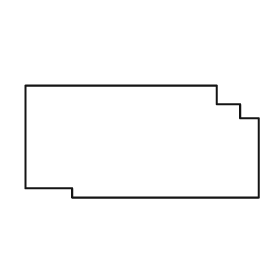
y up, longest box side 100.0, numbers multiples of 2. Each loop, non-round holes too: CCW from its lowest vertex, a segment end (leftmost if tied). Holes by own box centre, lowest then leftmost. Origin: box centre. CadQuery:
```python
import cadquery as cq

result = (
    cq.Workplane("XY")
    .moveTo(-30.0, -24.0)
    .lineTo(50.0, -24.0)
    .lineTo(50.0, 10.0)
    .lineTo(42.0, 10.0)
    .lineTo(42.0, 16.0)
    .lineTo(32.0, 16.0)
    .lineTo(32.0, 24.0)
    .lineTo(-50.0, 24.0)
    .lineTo(-50.0, -20.0)
    .lineTo(-30.0, -20.0)
    .close()
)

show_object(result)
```